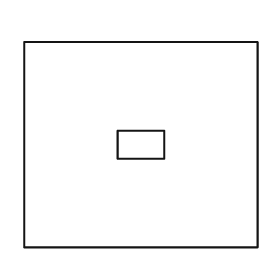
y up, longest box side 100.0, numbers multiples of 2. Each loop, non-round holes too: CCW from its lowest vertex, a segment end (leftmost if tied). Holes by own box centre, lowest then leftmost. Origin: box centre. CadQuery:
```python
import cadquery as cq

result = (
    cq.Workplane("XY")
    .moveTo(-50.0, -44.0)
    .lineTo(50.0, -44.0)
    .lineTo(50.0, 44.0)
    .lineTo(-50.0, 44.0)
    .close()
    .moveTo(-10.0, -6.0)
    .lineTo(10.0, -6.0)
    .lineTo(10.0, 6.0)
    .lineTo(-10.0, 6.0)
    .close()
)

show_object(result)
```